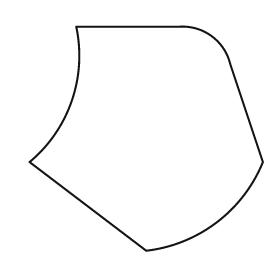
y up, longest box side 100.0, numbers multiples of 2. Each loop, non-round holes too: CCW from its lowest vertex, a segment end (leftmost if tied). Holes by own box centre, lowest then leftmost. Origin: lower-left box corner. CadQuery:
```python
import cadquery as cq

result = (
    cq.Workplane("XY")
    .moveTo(50.0, 0.0)
    .threePointArc((80.0, 12.0), (100.0, 38.0))
    .lineTo(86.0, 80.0)
    .threePointArc((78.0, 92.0), (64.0, 96.0))
    .lineTo(20.0, 96.0)
    .threePointArc((18.0, 64.0), (0.0, 38.0))
    .close()
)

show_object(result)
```